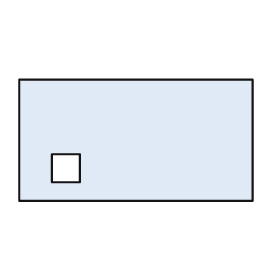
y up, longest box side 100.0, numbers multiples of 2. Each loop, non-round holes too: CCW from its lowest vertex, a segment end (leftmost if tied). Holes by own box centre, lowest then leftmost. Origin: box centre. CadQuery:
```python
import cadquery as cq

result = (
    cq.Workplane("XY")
    .moveTo(-50.0, -26.0)
    .lineTo(50.0, -26.0)
    .lineTo(50.0, 26.0)
    .lineTo(-50.0, 26.0)
    .close()
    .moveTo(-36.0, -18.0)
    .lineTo(-24.0, -18.0)
    .lineTo(-24.0, -6.0)
    .lineTo(-36.0, -6.0)
    .close()
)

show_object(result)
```